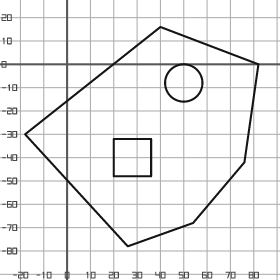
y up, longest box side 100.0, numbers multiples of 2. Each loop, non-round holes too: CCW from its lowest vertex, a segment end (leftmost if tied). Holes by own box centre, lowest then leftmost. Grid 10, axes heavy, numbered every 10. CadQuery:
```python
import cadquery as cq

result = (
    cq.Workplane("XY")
    .moveTo(26.0, -78.0)
    .lineTo(54.0, -68.0)
    .lineTo(76.0, -42.0)
    .lineTo(82.0, 0.0)
    .lineTo(40.0, 16.0)
    .lineTo(-18.0, -30.0)
    .close()
    .moveTo(20.0, -48.0)
    .lineTo(36.0, -48.0)
    .lineTo(36.0, -32.0)
    .lineTo(20.0, -32.0)
    .close()
    .moveTo(50.0, -8.0)
    .circle(8.0)
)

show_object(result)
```